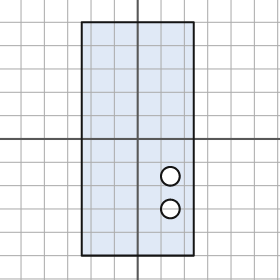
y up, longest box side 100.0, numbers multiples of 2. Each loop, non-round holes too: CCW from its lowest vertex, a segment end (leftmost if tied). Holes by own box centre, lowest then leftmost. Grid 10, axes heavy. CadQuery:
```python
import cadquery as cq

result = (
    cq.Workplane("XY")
    .moveTo(-24.0, -50.0)
    .lineTo(24.0, -50.0)
    .lineTo(24.0, 50.0)
    .lineTo(-24.0, 50.0)
    .close()
    .moveTo(14.0, -30.0)
    .circle(4.0)
    .moveTo(14.0, -16.0)
    .circle(4.0)
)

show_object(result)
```